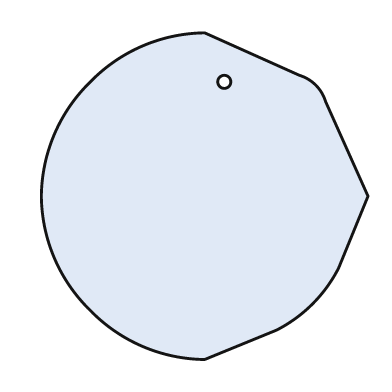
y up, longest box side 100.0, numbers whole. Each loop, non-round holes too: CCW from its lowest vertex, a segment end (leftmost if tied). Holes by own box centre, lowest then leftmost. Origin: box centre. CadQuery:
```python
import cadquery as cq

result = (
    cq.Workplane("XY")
    .moveTo(0.0, -50.0)
    .lineTo(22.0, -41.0)
    .threePointArc((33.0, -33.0), (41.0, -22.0))
    .lineTo(50.0, 0.0)
    .lineTo(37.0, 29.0)
    .threePointArc((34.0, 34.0), (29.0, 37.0))
    .lineTo(0.0, 50.0)
    .threePointArc((-19.0, 46.0), (-35.0, 35.0))
    .threePointArc((-46.0, 19.0), (-50.0, 0.0))
    .threePointArc((-46.0, -19.0), (-35.0, -35.0))
    .threePointArc((-19.0, -46.0), (0.0, -50.0))
    .close()
    .moveTo(6.0, 35.0)
    .circle(2.0)
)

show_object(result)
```